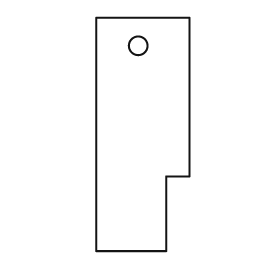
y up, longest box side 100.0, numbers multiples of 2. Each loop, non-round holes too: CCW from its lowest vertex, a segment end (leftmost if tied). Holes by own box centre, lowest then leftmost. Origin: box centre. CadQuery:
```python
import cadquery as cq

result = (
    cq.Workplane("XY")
    .moveTo(-20.0, -50.0)
    .lineTo(10.0, -50.0)
    .lineTo(10.0, -18.0)
    .lineTo(20.0, -18.0)
    .lineTo(20.0, 50.0)
    .lineTo(-20.0, 50.0)
    .close()
    .moveTo(-2.0, 38.0)
    .circle(4.0)
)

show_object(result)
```